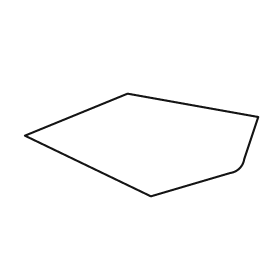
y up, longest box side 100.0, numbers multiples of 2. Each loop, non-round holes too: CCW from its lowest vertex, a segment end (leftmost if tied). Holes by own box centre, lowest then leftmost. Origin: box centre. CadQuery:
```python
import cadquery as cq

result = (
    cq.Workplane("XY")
    .moveTo(4.0, -22.0)
    .lineTo(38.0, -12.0)
    .threePointArc((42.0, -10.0), (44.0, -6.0))
    .lineTo(50.0, 12.0)
    .lineTo(-6.0, 22.0)
    .lineTo(-50.0, 4.0)
    .close()
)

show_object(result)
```